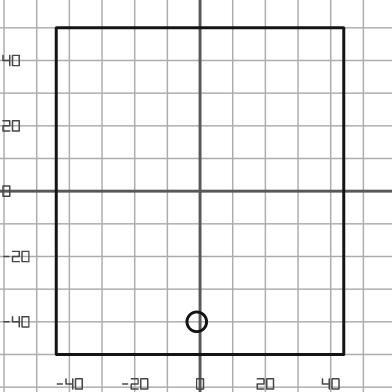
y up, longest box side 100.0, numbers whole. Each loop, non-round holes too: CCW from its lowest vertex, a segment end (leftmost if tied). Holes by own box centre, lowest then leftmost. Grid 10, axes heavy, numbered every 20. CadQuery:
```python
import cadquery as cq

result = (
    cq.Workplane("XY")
    .moveTo(-44.0, -50.0)
    .lineTo(44.0, -50.0)
    .lineTo(44.0, 50.0)
    .lineTo(-44.0, 50.0)
    .close()
    .moveTo(-1.0, -40.0)
    .circle(3.0)
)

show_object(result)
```